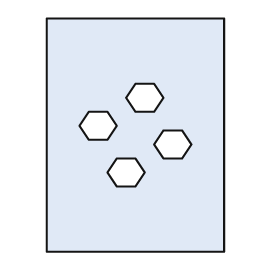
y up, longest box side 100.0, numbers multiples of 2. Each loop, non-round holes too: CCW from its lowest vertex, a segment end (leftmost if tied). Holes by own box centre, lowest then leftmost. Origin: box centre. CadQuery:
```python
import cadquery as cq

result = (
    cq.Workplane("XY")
    .moveTo(-38.0, -50.0)
    .lineTo(38.0, -50.0)
    .lineTo(38.0, 50.0)
    .lineTo(-38.0, 50.0)
    .close()
    .moveTo(-8.0, -22.0)
    .lineTo(0.0, -22.0)
    .lineTo(4.0, -16.0)
    .lineTo(0.0, -10.0)
    .lineTo(-8.0, -10.0)
    .lineTo(-12.0, -16.0)
    .close()
    .moveTo(12.0, -10.0)
    .lineTo(20.0, -10.0)
    .lineTo(24.0, -4.0)
    .lineTo(20.0, 2.0)
    .lineTo(12.0, 2.0)
    .lineTo(8.0, -4.0)
    .close()
    .moveTo(-20.0, -2.0)
    .lineTo(-12.0, -2.0)
    .lineTo(-8.0, 4.0)
    .lineTo(-12.0, 10.0)
    .lineTo(-20.0, 10.0)
    .lineTo(-24.0, 4.0)
    .close()
    .moveTo(0.0, 10.0)
    .lineTo(8.0, 10.0)
    .lineTo(12.0, 16.0)
    .lineTo(8.0, 22.0)
    .lineTo(0.0, 22.0)
    .lineTo(-4.0, 16.0)
    .close()
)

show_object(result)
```